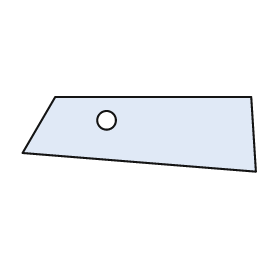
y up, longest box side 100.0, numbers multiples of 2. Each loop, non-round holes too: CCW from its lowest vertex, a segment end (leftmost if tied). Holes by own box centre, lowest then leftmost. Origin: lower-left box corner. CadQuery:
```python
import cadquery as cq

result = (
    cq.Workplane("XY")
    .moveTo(100.0, 0.0)
    .lineTo(98.0, 32.0)
    .lineTo(14.0, 32.0)
    .lineTo(0.0, 8.0)
    .close()
    .moveTo(36.0, 22.0)
    .circle(4.0)
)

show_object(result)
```